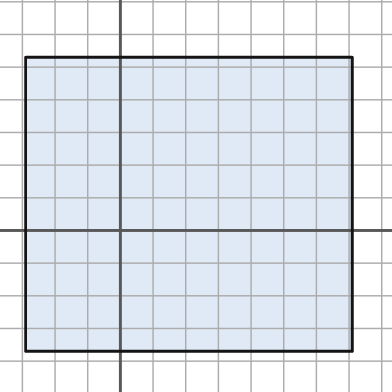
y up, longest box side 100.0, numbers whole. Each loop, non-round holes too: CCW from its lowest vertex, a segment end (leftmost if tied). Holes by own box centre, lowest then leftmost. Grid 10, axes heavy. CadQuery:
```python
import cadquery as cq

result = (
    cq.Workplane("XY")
    .moveTo(-29.0, -37.0)
    .lineTo(71.0, -37.0)
    .lineTo(71.0, 53.0)
    .lineTo(-29.0, 53.0)
    .close()
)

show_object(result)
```